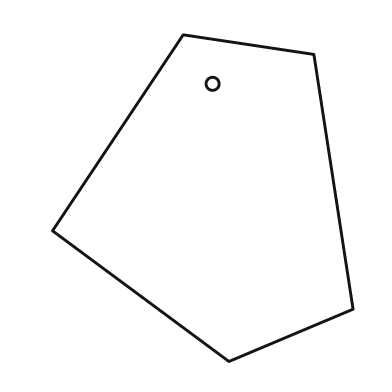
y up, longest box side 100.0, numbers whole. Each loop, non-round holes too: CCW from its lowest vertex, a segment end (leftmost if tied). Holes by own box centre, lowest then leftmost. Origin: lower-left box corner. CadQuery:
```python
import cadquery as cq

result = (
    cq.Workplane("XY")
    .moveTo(54.0, 0.0)
    .lineTo(92.0, 16.0)
    .lineTo(80.0, 94.0)
    .lineTo(40.0, 100.0)
    .lineTo(0.0, 40.0)
    .close()
    .moveTo(49.0, 85.0)
    .circle(2.0)
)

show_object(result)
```